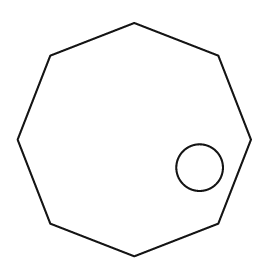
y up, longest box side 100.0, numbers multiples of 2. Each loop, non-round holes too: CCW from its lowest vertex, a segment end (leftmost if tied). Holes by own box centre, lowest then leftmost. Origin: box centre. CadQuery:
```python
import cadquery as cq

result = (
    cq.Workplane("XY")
    .moveTo(0.0, -50.0)
    .lineTo(36.0, -36.0)
    .lineTo(50.0, 0.0)
    .lineTo(36.0, 36.0)
    .lineTo(0.0, 50.0)
    .lineTo(-36.0, 36.0)
    .lineTo(-50.0, 0.0)
    .lineTo(-36.0, -36.0)
    .close()
    .moveTo(28.0, -12.0)
    .circle(10.0)
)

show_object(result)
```